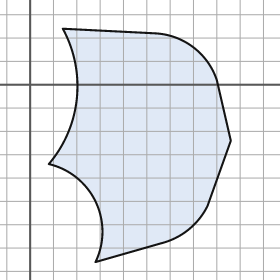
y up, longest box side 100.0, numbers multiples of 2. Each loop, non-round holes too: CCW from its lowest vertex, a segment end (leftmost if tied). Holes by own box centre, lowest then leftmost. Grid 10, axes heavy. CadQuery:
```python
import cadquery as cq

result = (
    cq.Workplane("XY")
    .moveTo(28.0, -76.0)
    .lineTo(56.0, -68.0)
    .threePointArc((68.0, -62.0), (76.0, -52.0))
    .lineTo(86.0, -24.0)
    .lineTo(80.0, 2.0)
    .threePointArc((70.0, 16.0), (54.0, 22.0))
    .lineTo(14.0, 24.0)
    .threePointArc((20.0, -6.0), (8.0, -34.0))
    .threePointArc((28.0, -50.0), (28.0, -76.0))
    .close()
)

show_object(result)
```